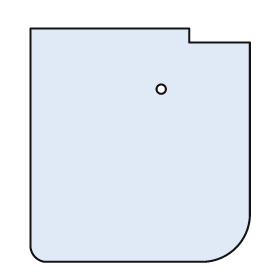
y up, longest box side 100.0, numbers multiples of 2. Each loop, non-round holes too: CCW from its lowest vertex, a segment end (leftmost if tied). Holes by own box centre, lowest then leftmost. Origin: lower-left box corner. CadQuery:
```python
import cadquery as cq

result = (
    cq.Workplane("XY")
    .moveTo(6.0, 0.0)
    .lineTo(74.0, 0.0)
    .threePointArc((88.0, 6.0), (94.0, 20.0))
    .lineTo(94.0, 94.0)
    .lineTo(68.0, 94.0)
    .lineTo(68.0, 100.0)
    .lineTo(0.0, 100.0)
    .lineTo(0.0, 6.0)
    .threePointArc((2.0, 2.0), (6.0, 0.0))
    .close()
    .moveTo(56.0, 74.0)
    .circle(2.0)
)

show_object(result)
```